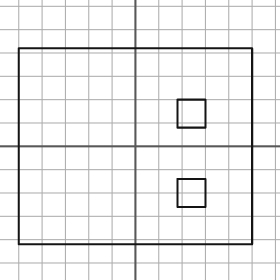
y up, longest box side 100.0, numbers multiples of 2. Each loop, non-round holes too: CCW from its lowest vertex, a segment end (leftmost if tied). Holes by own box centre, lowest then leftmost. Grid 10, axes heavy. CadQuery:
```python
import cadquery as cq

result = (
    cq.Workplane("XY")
    .moveTo(-50.0, -42.0)
    .lineTo(50.0, -42.0)
    .lineTo(50.0, 42.0)
    .lineTo(-50.0, 42.0)
    .close()
    .moveTo(18.0, -26.0)
    .lineTo(30.0, -26.0)
    .lineTo(30.0, -14.0)
    .lineTo(18.0, -14.0)
    .close()
    .moveTo(18.0, 8.0)
    .lineTo(30.0, 8.0)
    .lineTo(30.0, 20.0)
    .lineTo(18.0, 20.0)
    .close()
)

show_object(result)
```